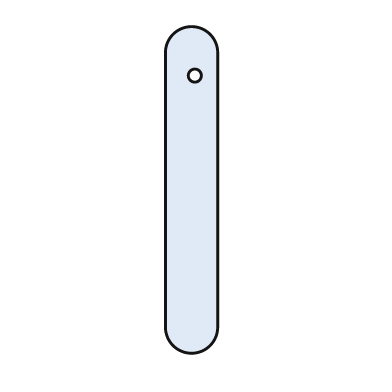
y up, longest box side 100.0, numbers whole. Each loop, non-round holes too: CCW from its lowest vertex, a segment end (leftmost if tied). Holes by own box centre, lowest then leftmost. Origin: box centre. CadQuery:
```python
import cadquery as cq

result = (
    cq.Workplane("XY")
    .moveTo(-8.0, -42.0)
    .threePointArc((0.0, -50.0), (8.0, -42.0))
    .lineTo(8.0, 42.0)
    .threePointArc((0.0, 50.0), (-8.0, 42.0))
    .close()
    .moveTo(1.0, 35.0)
    .circle(2.0)
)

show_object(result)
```